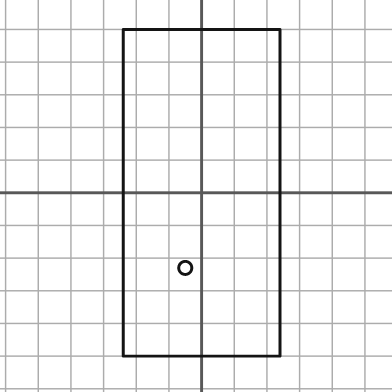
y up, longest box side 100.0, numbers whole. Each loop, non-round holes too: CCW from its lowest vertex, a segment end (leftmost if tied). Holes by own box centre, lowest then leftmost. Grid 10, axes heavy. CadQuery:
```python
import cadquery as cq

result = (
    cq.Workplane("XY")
    .moveTo(-24.0, -50.0)
    .lineTo(24.0, -50.0)
    .lineTo(24.0, 50.0)
    .lineTo(-24.0, 50.0)
    .close()
    .moveTo(-5.0, -23.0)
    .circle(2.0)
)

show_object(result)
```